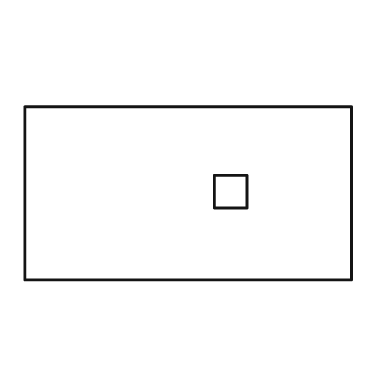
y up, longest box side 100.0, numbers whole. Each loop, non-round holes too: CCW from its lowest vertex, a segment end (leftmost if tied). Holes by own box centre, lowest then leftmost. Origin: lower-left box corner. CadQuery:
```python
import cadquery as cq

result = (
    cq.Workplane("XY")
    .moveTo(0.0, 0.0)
    .lineTo(100.0, 0.0)
    .lineTo(100.0, 53.0)
    .lineTo(0.0, 53.0)
    .close()
    .moveTo(58.0, 22.0)
    .lineTo(68.0, 22.0)
    .lineTo(68.0, 32.0)
    .lineTo(58.0, 32.0)
    .close()
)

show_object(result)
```